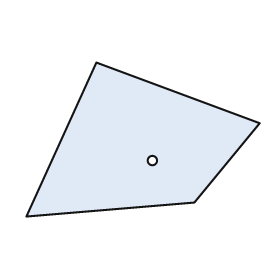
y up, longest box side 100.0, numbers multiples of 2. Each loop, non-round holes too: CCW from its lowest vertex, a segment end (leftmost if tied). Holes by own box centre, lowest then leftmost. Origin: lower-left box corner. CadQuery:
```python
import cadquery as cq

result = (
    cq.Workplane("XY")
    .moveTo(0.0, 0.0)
    .lineTo(72.0, 6.0)
    .lineTo(100.0, 40.0)
    .lineTo(30.0, 66.0)
    .close()
    .moveTo(54.0, 24.0)
    .circle(2.0)
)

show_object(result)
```